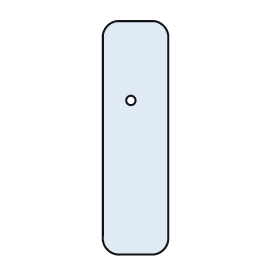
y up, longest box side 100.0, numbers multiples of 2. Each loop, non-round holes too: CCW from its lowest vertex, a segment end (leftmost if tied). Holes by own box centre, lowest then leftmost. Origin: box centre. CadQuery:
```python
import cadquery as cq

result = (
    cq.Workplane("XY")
    .moveTo(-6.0, -50.0)
    .lineTo(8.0, -50.0)
    .threePointArc((12.0, -48.0), (14.0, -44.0))
    .lineTo(14.0, 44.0)
    .threePointArc((12.0, 48.0), (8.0, 50.0))
    .lineTo(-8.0, 50.0)
    .threePointArc((-12.0, 48.0), (-14.0, 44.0))
    .lineTo(-14.0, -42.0)
    .threePointArc((-12.0, -48.0), (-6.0, -50.0))
    .close()
    .moveTo(-2.0, 16.0)
    .circle(2.0)
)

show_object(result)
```